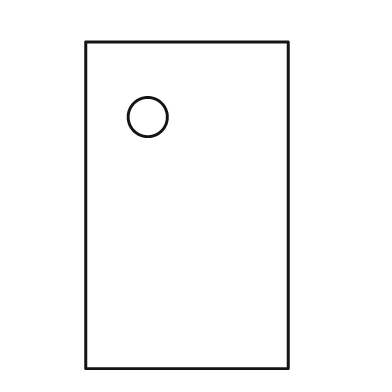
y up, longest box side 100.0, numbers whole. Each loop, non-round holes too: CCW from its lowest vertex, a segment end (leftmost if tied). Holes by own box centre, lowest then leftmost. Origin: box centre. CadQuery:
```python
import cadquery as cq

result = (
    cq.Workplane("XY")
    .moveTo(-31.0, -50.0)
    .lineTo(31.0, -50.0)
    .lineTo(31.0, 50.0)
    .lineTo(-31.0, 50.0)
    .close()
    .moveTo(-12.0, 27.0)
    .circle(6.0)
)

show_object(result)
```